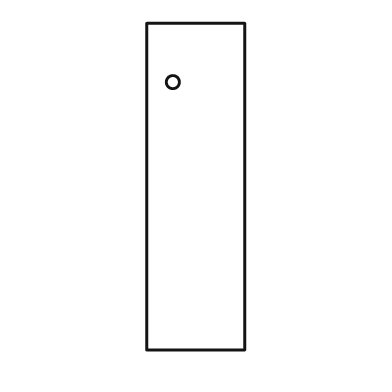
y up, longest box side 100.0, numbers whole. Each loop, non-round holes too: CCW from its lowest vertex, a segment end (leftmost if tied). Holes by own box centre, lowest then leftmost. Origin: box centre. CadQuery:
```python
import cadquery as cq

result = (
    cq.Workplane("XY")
    .moveTo(-15.0, -50.0)
    .lineTo(15.0, -50.0)
    .lineTo(15.0, 50.0)
    .lineTo(-15.0, 50.0)
    .close()
    .moveTo(-7.0, 32.0)
    .circle(2.0)
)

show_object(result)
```